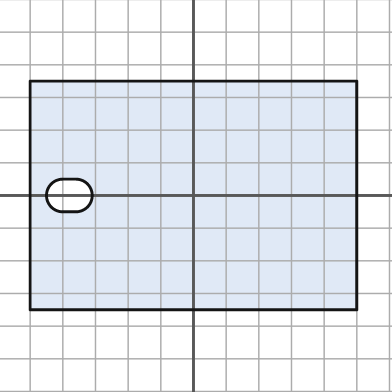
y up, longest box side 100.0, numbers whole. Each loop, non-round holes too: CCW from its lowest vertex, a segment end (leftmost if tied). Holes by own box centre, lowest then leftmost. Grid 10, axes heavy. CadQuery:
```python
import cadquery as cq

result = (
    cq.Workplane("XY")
    .moveTo(-50.0, -35.0)
    .lineTo(50.0, -35.0)
    .lineTo(50.0, 35.0)
    .lineTo(-50.0, 35.0)
    .close()
    .moveTo(-40.0, -5.0)
    .lineTo(-36.0, -5.0)
    .threePointArc((-31.0, 0.0), (-36.0, 5.0))
    .lineTo(-40.0, 5.0)
    .threePointArc((-45.0, 0.0), (-40.0, -5.0))
    .close()
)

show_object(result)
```